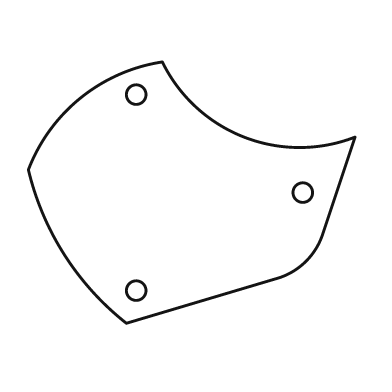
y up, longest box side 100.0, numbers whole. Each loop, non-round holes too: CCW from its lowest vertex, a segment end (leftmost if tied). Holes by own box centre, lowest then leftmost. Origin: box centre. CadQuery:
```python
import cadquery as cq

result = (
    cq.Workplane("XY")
    .moveTo(-20.0, -40.0)
    .lineTo(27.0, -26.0)
    .threePointArc((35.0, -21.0), (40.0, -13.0))
    .lineTo(50.0, 17.0)
    .threePointArc((16.0, 17.0), (-9.0, 40.0))
    .threePointArc((-34.0, 29.0), (-50.0, 7.0))
    .threePointArc((-39.0, -19.0), (-20.0, -40.0))
    .close()
    .moveTo(-17.0, -30.0)
    .circle(3.0)
    .moveTo(34.0, 0.0)
    .circle(3.0)
    .moveTo(-17.0, 30.0)
    .circle(3.0)
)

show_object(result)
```